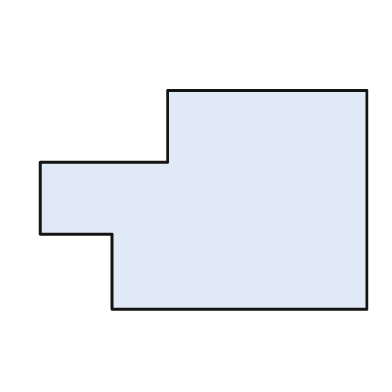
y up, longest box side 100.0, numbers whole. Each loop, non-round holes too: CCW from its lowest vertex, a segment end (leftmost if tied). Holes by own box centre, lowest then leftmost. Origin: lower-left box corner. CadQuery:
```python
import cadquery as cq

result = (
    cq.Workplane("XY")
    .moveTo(22.0, 0.0)
    .lineTo(100.0, 0.0)
    .lineTo(100.0, 67.0)
    .lineTo(39.0, 67.0)
    .lineTo(39.0, 45.0)
    .lineTo(0.0, 45.0)
    .lineTo(0.0, 23.0)
    .lineTo(22.0, 23.0)
    .close()
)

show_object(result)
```